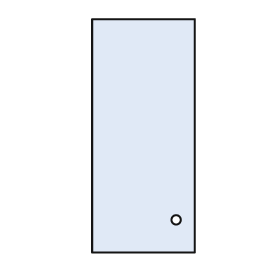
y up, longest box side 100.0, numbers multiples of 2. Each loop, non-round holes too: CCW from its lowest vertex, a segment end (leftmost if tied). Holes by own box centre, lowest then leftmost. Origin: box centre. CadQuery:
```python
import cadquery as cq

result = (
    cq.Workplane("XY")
    .moveTo(-22.0, -50.0)
    .lineTo(22.0, -50.0)
    .lineTo(22.0, 50.0)
    .lineTo(-22.0, 50.0)
    .close()
    .moveTo(14.0, -36.0)
    .circle(2.0)
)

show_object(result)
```